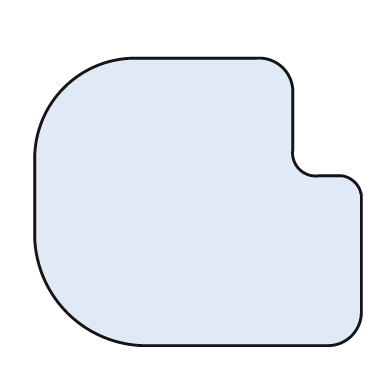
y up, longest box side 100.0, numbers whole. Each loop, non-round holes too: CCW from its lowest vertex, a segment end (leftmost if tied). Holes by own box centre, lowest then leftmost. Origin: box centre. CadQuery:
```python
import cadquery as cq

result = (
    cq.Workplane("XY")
    .moveTo(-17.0, -44.0)
    .lineTo(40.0, -44.0)
    .threePointArc((47.0, -41.0), (50.0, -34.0))
    .lineTo(50.0, 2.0)
    .threePointArc((48.0, 6.0), (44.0, 8.0))
    .lineTo(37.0, 8.0)
    .threePointArc((31.0, 10.0), (29.0, 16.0))
    .lineTo(29.0, 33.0)
    .threePointArc((26.0, 41.0), (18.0, 44.0))
    .lineTo(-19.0, 44.0)
    .threePointArc((-41.0, 35.0), (-50.0, 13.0))
    .lineTo(-50.0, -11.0)
    .threePointArc((-40.0, -34.0), (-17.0, -44.0))
    .close()
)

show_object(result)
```